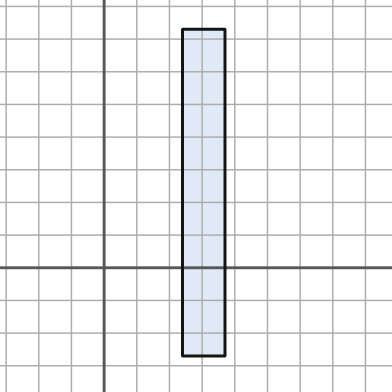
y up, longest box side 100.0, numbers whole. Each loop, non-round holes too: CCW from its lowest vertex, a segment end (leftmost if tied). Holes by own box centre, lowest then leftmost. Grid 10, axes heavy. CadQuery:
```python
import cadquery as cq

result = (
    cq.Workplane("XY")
    .moveTo(24.0, -27.0)
    .lineTo(37.0, -27.0)
    .lineTo(37.0, 73.0)
    .lineTo(24.0, 73.0)
    .close()
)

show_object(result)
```